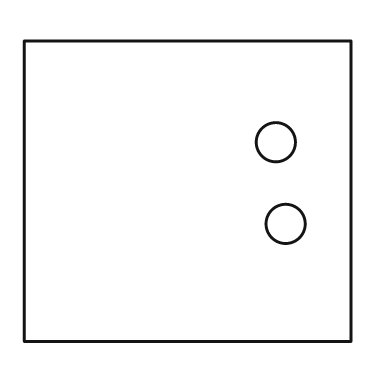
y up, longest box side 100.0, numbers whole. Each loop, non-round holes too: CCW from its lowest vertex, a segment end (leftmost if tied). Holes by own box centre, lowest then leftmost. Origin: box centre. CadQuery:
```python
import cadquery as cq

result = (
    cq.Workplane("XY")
    .moveTo(-50.0, -46.0)
    .lineTo(50.0, -46.0)
    .lineTo(50.0, 46.0)
    .lineTo(-50.0, 46.0)
    .close()
    .moveTo(30.0, -10.0)
    .circle(6.0)
    .moveTo(27.0, 15.0)
    .circle(6.0)
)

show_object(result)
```